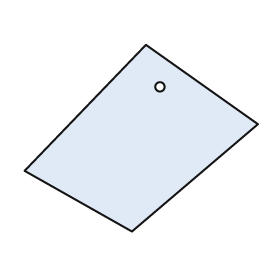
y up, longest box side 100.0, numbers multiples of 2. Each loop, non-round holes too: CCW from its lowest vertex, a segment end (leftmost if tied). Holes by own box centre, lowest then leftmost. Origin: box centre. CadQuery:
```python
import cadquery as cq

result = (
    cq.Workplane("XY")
    .moveTo(-4.0, -40.0)
    .lineTo(50.0, 6.0)
    .lineTo(2.0, 40.0)
    .lineTo(-50.0, -14.0)
    .close()
    .moveTo(8.0, 22.0)
    .circle(2.0)
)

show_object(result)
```